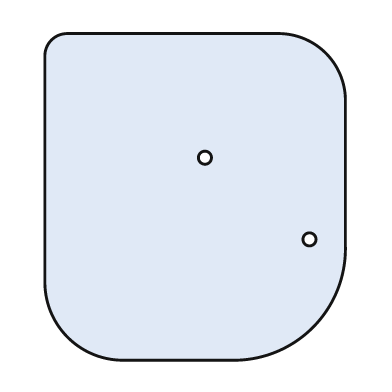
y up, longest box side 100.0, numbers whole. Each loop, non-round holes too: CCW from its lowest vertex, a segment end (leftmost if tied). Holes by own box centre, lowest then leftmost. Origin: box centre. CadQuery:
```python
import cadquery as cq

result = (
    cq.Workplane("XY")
    .moveTo(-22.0, -50.0)
    .lineTo(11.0, -50.0)
    .threePointArc((36.0, -40.0), (46.0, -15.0))
    .lineTo(46.0, 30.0)
    .threePointArc((40.0, 44.0), (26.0, 50.0))
    .lineTo(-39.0, 50.0)
    .threePointArc((-44.0, 48.0), (-46.0, 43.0))
    .lineTo(-46.0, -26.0)
    .threePointArc((-39.0, -43.0), (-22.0, -50.0))
    .close()
    .moveTo(35.0, -13.0)
    .circle(2.0)
    .moveTo(3.0, 12.0)
    .circle(2.0)
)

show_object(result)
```